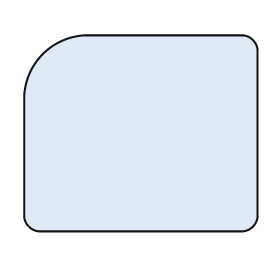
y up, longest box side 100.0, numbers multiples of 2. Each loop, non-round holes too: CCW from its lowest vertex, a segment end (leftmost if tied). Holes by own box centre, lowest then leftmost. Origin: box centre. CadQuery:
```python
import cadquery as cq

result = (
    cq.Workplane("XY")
    .moveTo(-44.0, -42.0)
    .lineTo(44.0, -42.0)
    .threePointArc((48.0, -40.0), (50.0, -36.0))
    .lineTo(50.0, 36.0)
    .threePointArc((48.0, 40.0), (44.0, 42.0))
    .lineTo(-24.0, 42.0)
    .threePointArc((-42.0, 34.0), (-50.0, 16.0))
    .lineTo(-50.0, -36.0)
    .threePointArc((-48.0, -40.0), (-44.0, -42.0))
    .close()
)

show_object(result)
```